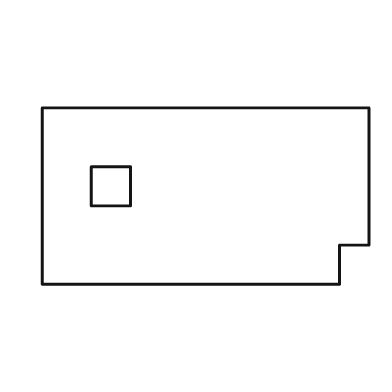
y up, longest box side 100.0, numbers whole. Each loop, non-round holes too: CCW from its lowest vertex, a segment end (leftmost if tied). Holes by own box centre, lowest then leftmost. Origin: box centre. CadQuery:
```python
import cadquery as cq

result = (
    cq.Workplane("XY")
    .moveTo(-50.0, -27.0)
    .lineTo(41.0, -27.0)
    .lineTo(41.0, -15.0)
    .lineTo(50.0, -15.0)
    .lineTo(50.0, 27.0)
    .lineTo(-50.0, 27.0)
    .close()
    .moveTo(-35.0, -3.0)
    .lineTo(-23.0, -3.0)
    .lineTo(-23.0, 9.0)
    .lineTo(-35.0, 9.0)
    .close()
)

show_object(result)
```